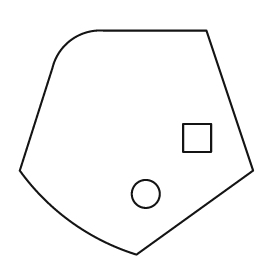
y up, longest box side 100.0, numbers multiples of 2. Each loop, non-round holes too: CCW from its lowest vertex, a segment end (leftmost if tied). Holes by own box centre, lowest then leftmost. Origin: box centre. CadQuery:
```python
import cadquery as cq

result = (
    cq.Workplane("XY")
    .moveTo(0.0, -48.0)
    .lineTo(50.0, -12.0)
    .lineTo(30.0, 48.0)
    .lineTo(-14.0, 48.0)
    .threePointArc((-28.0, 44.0), (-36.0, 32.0))
    .lineTo(-50.0, -12.0)
    .threePointArc((-28.0, -34.0), (0.0, -48.0))
    .close()
    .moveTo(4.0, -22.0)
    .circle(6.0)
    .moveTo(20.0, -4.0)
    .lineTo(32.0, -4.0)
    .lineTo(32.0, 8.0)
    .lineTo(20.0, 8.0)
    .close()
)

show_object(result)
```